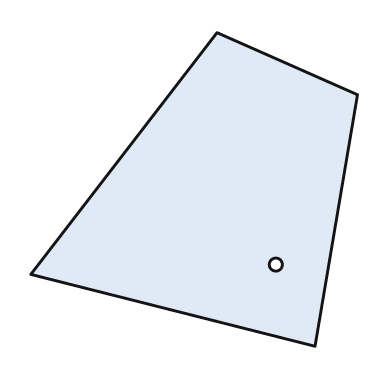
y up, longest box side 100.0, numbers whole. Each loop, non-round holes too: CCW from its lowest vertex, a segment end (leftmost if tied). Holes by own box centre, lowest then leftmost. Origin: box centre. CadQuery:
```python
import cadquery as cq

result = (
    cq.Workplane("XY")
    .moveTo(37.0, -48.0)
    .lineTo(50.0, 29.0)
    .lineTo(7.0, 48.0)
    .lineTo(-50.0, -26.0)
    .close()
    .moveTo(25.0, -23.0)
    .circle(2.0)
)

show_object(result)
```